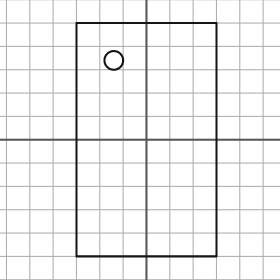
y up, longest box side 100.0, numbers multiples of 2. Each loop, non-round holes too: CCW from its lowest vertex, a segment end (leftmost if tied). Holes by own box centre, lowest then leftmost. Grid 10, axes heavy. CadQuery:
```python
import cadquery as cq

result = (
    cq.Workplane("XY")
    .moveTo(-30.0, -50.0)
    .lineTo(30.0, -50.0)
    .lineTo(30.0, 50.0)
    .lineTo(-30.0, 50.0)
    .close()
    .moveTo(-14.0, 34.0)
    .circle(4.0)
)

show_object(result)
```